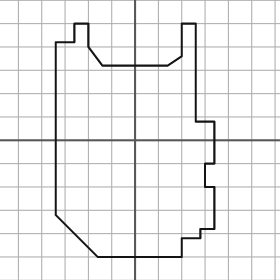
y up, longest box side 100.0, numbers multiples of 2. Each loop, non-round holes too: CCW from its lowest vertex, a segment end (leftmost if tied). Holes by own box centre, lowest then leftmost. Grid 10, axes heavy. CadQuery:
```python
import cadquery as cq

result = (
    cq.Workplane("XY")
    .moveTo(-16.0, -50.0)
    .lineTo(20.0, -50.0)
    .lineTo(20.0, -42.0)
    .lineTo(28.0, -42.0)
    .lineTo(28.0, -38.0)
    .lineTo(34.0, -38.0)
    .lineTo(34.0, -20.0)
    .lineTo(30.0, -20.0)
    .lineTo(30.0, -10.0)
    .lineTo(34.0, -10.0)
    .lineTo(34.0, 8.0)
    .lineTo(26.0, 8.0)
    .lineTo(26.0, 50.0)
    .lineTo(20.0, 50.0)
    .lineTo(20.0, 36.0)
    .lineTo(14.0, 32.0)
    .lineTo(-14.0, 32.0)
    .lineTo(-20.0, 40.0)
    .lineTo(-20.0, 50.0)
    .lineTo(-26.0, 50.0)
    .lineTo(-26.0, 42.0)
    .lineTo(-34.0, 42.0)
    .lineTo(-34.0, -32.0)
    .close()
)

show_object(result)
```